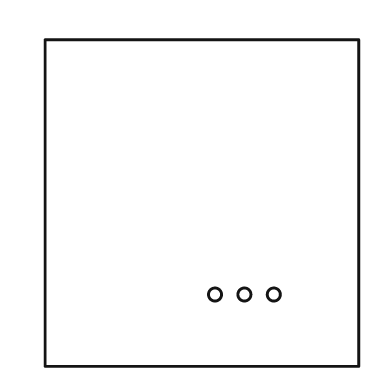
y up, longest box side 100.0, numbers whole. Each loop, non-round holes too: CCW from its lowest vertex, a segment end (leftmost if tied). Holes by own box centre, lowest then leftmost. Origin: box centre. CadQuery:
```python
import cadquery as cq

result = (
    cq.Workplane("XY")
    .moveTo(-48.0, -50.0)
    .lineTo(48.0, -50.0)
    .lineTo(48.0, 50.0)
    .lineTo(-48.0, 50.0)
    .close()
    .moveTo(4.0, -28.0)
    .circle(2.0)
    .moveTo(13.0, -28.0)
    .circle(2.0)
    .moveTo(22.0, -28.0)
    .circle(2.0)
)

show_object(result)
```